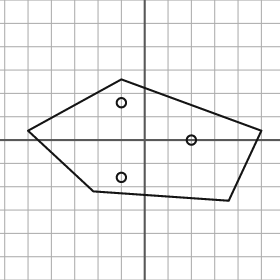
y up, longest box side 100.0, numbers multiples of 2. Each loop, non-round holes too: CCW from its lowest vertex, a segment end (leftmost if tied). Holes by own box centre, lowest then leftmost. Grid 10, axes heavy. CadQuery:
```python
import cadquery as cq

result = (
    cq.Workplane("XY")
    .moveTo(36.0, -26.0)
    .lineTo(50.0, 4.0)
    .lineTo(-10.0, 26.0)
    .lineTo(-50.0, 4.0)
    .lineTo(-22.0, -22.0)
    .close()
    .moveTo(-10.0, -16.0)
    .circle(2.0)
    .moveTo(20.0, 0.0)
    .circle(2.0)
    .moveTo(-10.0, 16.0)
    .circle(2.0)
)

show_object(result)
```